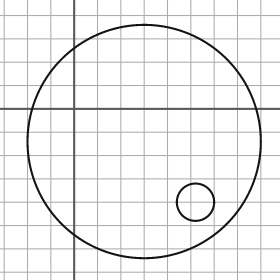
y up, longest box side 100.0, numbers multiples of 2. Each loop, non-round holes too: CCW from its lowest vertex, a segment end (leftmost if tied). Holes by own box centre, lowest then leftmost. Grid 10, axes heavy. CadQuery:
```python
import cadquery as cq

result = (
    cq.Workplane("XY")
    .moveTo(30.0, -14.0)
    .circle(50.0)
    .moveTo(52.0, -40.0)
    .circle(8.0)
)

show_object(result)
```